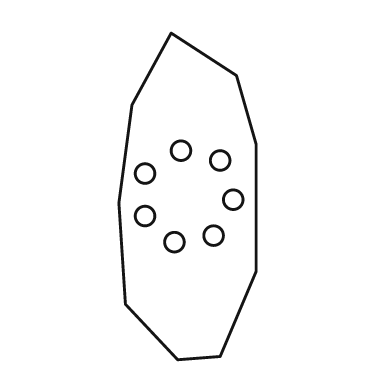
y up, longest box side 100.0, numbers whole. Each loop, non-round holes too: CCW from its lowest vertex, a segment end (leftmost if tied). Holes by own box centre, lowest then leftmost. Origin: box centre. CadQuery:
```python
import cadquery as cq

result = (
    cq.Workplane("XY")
    .moveTo(-3.0, -50.0)
    .lineTo(10.0, -49.0)
    .lineTo(21.0, -23.0)
    .lineTo(21.0, 16.0)
    .lineTo(15.0, 37.0)
    .lineTo(-5.0, 50.0)
    .lineTo(-17.0, 28.0)
    .lineTo(-21.0, -2.0)
    .lineTo(-19.0, -33.0)
    .close()
    .moveTo(-4.0, -14.0)
    .circle(3.0)
    .moveTo(8.0, -12.0)
    .circle(3.0)
    .moveTo(-13.0, -6.0)
    .circle(3.0)
    .moveTo(14.0, -1.0)
    .circle(3.0)
    .moveTo(-13.0, 7.0)
    .circle(3.0)
    .moveTo(10.0, 11.0)
    .circle(3.0)
    .moveTo(-2.0, 14.0)
    .circle(3.0)
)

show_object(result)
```